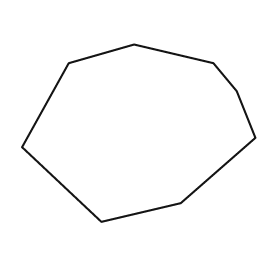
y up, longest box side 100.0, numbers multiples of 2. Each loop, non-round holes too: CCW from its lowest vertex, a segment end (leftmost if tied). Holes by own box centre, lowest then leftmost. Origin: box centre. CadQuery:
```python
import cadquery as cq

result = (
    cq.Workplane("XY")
    .moveTo(-16.0, -38.0)
    .lineTo(18.0, -30.0)
    .lineTo(50.0, -2.0)
    .lineTo(42.0, 18.0)
    .lineTo(32.0, 30.0)
    .lineTo(-2.0, 38.0)
    .lineTo(-30.0, 30.0)
    .lineTo(-50.0, -6.0)
    .close()
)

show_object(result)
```